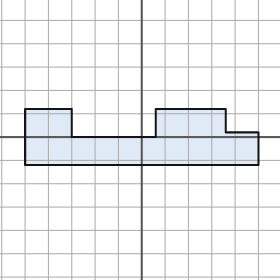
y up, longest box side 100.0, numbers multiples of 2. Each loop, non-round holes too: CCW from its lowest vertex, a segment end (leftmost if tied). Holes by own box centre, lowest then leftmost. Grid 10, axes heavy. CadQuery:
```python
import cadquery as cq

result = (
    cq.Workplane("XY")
    .moveTo(-50.0, -12.0)
    .lineTo(50.0, -12.0)
    .lineTo(50.0, 2.0)
    .lineTo(36.0, 2.0)
    .lineTo(36.0, 12.0)
    .lineTo(6.0, 12.0)
    .lineTo(6.0, 0.0)
    .lineTo(-30.0, 0.0)
    .lineTo(-30.0, 12.0)
    .lineTo(-50.0, 12.0)
    .close()
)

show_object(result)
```